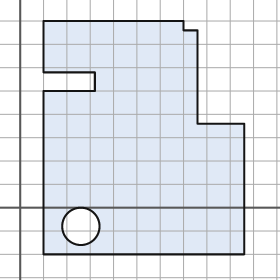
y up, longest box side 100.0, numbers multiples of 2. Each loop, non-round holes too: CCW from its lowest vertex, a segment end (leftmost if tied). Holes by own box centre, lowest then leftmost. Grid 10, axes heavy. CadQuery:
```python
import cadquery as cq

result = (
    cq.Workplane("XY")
    .moveTo(10.0, -20.0)
    .lineTo(96.0, -20.0)
    .lineTo(96.0, 36.0)
    .lineTo(76.0, 36.0)
    .lineTo(76.0, 76.0)
    .lineTo(70.0, 76.0)
    .lineTo(70.0, 80.0)
    .lineTo(10.0, 80.0)
    .lineTo(10.0, 58.0)
    .lineTo(32.0, 58.0)
    .lineTo(32.0, 50.0)
    .lineTo(10.0, 50.0)
    .close()
    .moveTo(26.0, -8.0)
    .circle(8.0)
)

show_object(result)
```